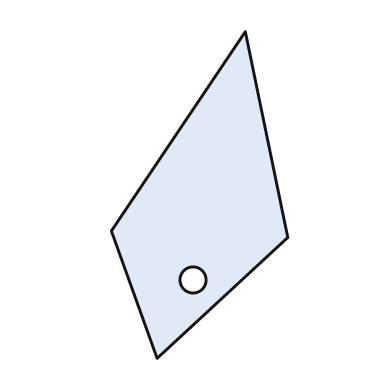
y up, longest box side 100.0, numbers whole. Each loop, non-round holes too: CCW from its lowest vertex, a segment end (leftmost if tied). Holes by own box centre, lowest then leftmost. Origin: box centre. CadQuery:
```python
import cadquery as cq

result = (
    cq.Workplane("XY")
    .moveTo(-13.0, -50.0)
    .lineTo(27.0, -13.0)
    .lineTo(14.0, 50.0)
    .lineTo(-27.0, -11.0)
    .close()
    .moveTo(-2.0, -26.0)
    .circle(4.0)
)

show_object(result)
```